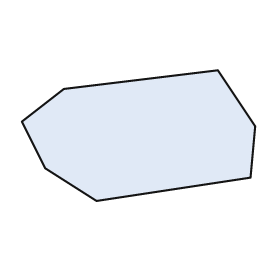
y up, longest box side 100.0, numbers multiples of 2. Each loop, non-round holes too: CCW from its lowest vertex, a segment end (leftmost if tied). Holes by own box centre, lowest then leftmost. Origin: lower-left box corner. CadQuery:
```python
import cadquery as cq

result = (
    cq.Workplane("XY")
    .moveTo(32.0, 0.0)
    .lineTo(98.0, 10.0)
    .lineTo(100.0, 32.0)
    .lineTo(84.0, 56.0)
    .lineTo(18.0, 48.0)
    .lineTo(0.0, 34.0)
    .lineTo(10.0, 14.0)
    .close()
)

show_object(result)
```